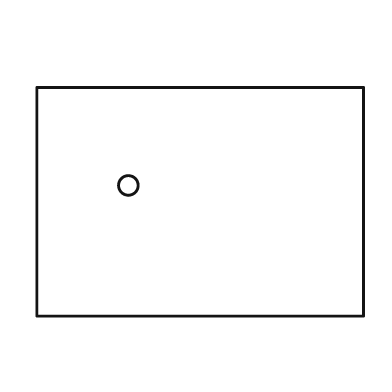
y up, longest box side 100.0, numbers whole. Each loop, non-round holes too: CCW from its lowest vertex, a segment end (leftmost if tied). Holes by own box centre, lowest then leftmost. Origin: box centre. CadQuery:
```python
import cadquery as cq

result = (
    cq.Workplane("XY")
    .moveTo(-50.0, -35.0)
    .lineTo(50.0, -35.0)
    .lineTo(50.0, 35.0)
    .lineTo(-50.0, 35.0)
    .close()
    .moveTo(-22.0, 5.0)
    .circle(3.0)
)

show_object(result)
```